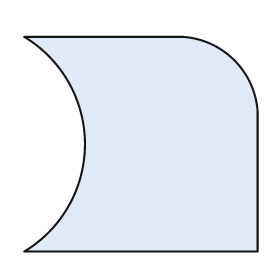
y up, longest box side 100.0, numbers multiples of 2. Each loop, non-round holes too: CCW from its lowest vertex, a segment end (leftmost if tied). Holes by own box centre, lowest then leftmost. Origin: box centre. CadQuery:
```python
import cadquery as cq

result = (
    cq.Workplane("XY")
    .moveTo(-50.0, -46.0)
    .lineTo(50.0, -46.0)
    .lineTo(50.0, 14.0)
    .threePointArc((40.0, 36.0), (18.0, 46.0))
    .lineTo(-50.0, 46.0)
    .threePointArc((-24.0, 0.0), (-50.0, -46.0))
    .close()
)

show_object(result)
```